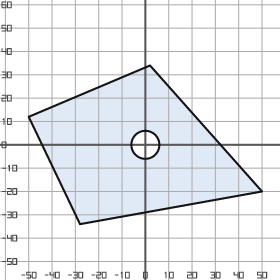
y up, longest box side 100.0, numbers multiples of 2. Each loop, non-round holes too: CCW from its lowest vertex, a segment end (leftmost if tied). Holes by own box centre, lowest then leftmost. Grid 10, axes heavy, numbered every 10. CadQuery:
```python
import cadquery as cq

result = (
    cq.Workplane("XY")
    .moveTo(-28.0, -34.0)
    .lineTo(50.0, -20.0)
    .lineTo(2.0, 34.0)
    .lineTo(-50.0, 12.0)
    .close()
    .moveTo(0.0, 0.0)
    .circle(6.0)
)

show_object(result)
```